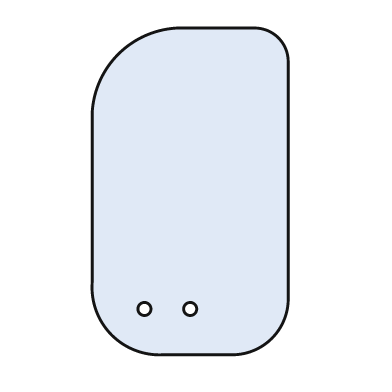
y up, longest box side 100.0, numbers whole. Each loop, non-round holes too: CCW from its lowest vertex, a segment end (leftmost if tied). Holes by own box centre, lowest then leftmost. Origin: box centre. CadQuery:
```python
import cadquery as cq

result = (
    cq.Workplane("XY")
    .moveTo(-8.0, -50.0)
    .lineTo(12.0, -50.0)
    .threePointArc((25.0, -45.0), (30.0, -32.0))
    .lineTo(30.0, 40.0)
    .threePointArc((27.0, 47.0), (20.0, 50.0))
    .lineTo(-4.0, 50.0)
    .threePointArc((-22.0, 42.0), (-30.0, 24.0))
    .lineTo(-30.0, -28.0)
    .threePointArc((-24.0, -44.0), (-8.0, -50.0))
    .close()
    .moveTo(-14.0, -36.0)
    .circle(2.0)
    .moveTo(0.0, -36.0)
    .circle(2.0)
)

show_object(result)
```